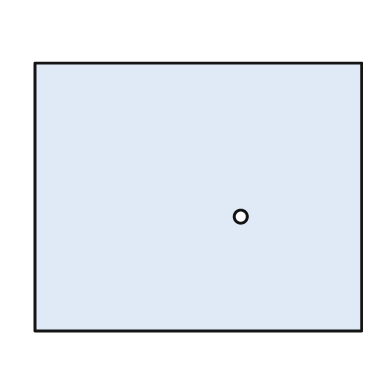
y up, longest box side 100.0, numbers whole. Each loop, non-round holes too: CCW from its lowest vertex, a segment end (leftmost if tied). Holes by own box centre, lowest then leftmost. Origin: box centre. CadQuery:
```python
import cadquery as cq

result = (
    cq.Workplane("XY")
    .moveTo(-50.0, -41.0)
    .lineTo(50.0, -41.0)
    .lineTo(50.0, 41.0)
    .lineTo(-50.0, 41.0)
    .close()
    .moveTo(13.0, -6.0)
    .circle(2.0)
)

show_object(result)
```